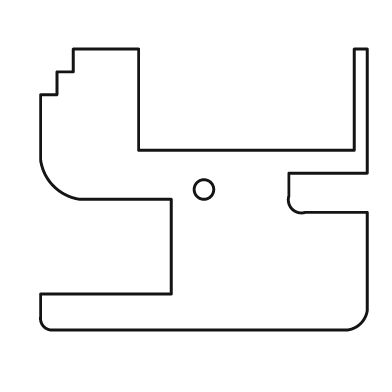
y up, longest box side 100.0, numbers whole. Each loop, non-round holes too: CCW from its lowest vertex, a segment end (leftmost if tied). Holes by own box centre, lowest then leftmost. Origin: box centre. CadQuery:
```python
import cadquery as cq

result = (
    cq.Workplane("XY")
    .moveTo(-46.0, -43.0)
    .lineTo(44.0, -43.0)
    .threePointArc((48.0, -41.0), (50.0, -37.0))
    .lineTo(50.0, -7.0)
    .lineTo(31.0, -7.0)
    .threePointArc((27.0, -6.0), (26.0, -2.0))
    .lineTo(26.0, 5.0)
    .lineTo(50.0, 5.0)
    .lineTo(50.0, 43.0)
    .lineTo(46.0, 43.0)
    .lineTo(46.0, 12.0)
    .lineTo(-20.0, 12.0)
    .lineTo(-20.0, 43.0)
    .lineTo(-40.0, 43.0)
    .lineTo(-40.0, 36.0)
    .lineTo(-45.0, 36.0)
    .lineTo(-45.0, 29.0)
    .lineTo(-50.0, 29.0)
    .lineTo(-50.0, 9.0)
    .threePointArc((-46.0, 1.0), (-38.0, -3.0))
    .lineTo(-10.0, -3.0)
    .lineTo(-10.0, -32.0)
    .lineTo(-50.0, -32.0)
    .lineTo(-50.0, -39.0)
    .threePointArc((-49.0, -42.0), (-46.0, -43.0))
    .close()
    .moveTo(0.0, 0.0)
    .circle(3.0)
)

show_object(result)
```